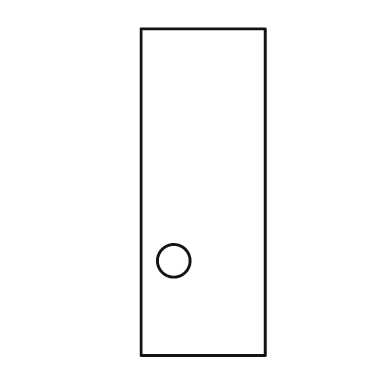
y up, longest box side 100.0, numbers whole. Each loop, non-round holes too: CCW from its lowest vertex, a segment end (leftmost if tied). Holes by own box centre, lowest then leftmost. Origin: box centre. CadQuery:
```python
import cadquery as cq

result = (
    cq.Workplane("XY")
    .moveTo(-19.0, -50.0)
    .lineTo(19.0, -50.0)
    .lineTo(19.0, 50.0)
    .lineTo(-19.0, 50.0)
    .close()
    .moveTo(-9.0, -21.0)
    .circle(5.0)
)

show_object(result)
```